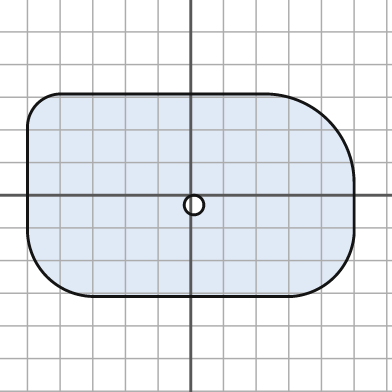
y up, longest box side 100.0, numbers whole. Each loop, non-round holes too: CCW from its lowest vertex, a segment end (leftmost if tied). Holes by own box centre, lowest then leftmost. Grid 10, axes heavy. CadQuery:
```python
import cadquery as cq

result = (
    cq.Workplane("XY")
    .moveTo(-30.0, -31.0)
    .lineTo(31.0, -31.0)
    .threePointArc((44.0, -25.0), (50.0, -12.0))
    .lineTo(50.0, 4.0)
    .threePointArc((42.0, 23.0), (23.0, 31.0))
    .lineTo(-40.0, 31.0)
    .threePointArc((-47.0, 28.0), (-50.0, 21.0))
    .lineTo(-50.0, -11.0)
    .threePointArc((-44.0, -25.0), (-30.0, -31.0))
    .close()
    .moveTo(1.0, -3.0)
    .circle(3.0)
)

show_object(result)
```